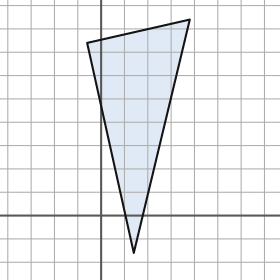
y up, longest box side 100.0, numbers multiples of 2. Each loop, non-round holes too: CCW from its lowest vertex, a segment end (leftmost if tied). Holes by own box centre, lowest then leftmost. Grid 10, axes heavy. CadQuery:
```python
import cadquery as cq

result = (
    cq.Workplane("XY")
    .moveTo(14.0, -16.0)
    .lineTo(38.0, 84.0)
    .lineTo(-6.0, 74.0)
    .close()
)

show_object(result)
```